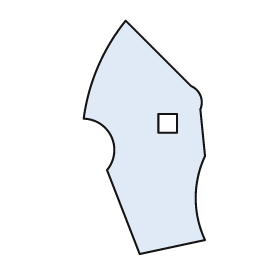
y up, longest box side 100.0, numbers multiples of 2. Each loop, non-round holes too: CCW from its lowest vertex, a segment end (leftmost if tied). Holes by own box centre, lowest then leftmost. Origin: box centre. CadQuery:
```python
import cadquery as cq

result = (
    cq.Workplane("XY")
    .moveTo(-2.0, -50.0)
    .lineTo(26.0, -44.0)
    .threePointArc((22.0, -26.0), (26.0, -8.0))
    .lineTo(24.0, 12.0)
    .threePointArc((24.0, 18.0), (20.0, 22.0))
    .lineTo(-8.0, 50.0)
    .threePointArc((-20.0, 30.0), (-26.0, 8.0))
    .threePointArc((-14.0, 0.0), (-16.0, -14.0))
    .close()
    .moveTo(6.0, 2.0)
    .lineTo(14.0, 2.0)
    .lineTo(14.0, 10.0)
    .lineTo(6.0, 10.0)
    .close()
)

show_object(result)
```